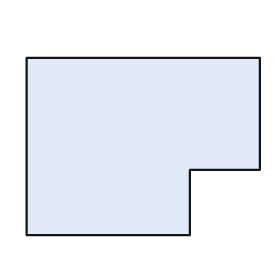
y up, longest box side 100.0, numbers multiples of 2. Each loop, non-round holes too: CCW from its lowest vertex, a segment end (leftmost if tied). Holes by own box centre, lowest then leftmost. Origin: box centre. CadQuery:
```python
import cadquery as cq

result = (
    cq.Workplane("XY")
    .moveTo(-50.0, -38.0)
    .lineTo(20.0, -38.0)
    .lineTo(20.0, -10.0)
    .lineTo(50.0, -10.0)
    .lineTo(50.0, 38.0)
    .lineTo(-50.0, 38.0)
    .close()
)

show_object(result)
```